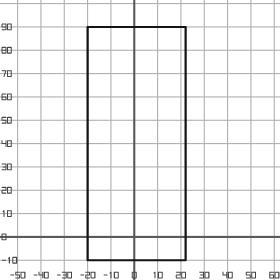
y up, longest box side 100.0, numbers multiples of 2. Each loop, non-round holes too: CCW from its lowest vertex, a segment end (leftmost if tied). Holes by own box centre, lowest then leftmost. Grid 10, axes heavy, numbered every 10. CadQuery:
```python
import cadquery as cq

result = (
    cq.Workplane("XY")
    .moveTo(-20.0, -10.0)
    .lineTo(22.0, -10.0)
    .lineTo(22.0, 90.0)
    .lineTo(-20.0, 90.0)
    .close()
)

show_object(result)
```